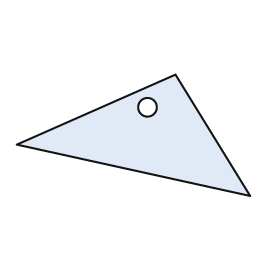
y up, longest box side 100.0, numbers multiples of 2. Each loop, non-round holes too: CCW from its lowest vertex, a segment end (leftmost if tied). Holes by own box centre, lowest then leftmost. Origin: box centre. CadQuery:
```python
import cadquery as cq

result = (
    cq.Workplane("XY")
    .moveTo(50.0, -26.0)
    .lineTo(18.0, 26.0)
    .lineTo(-50.0, -4.0)
    .close()
    .moveTo(6.0, 12.0)
    .circle(4.0)
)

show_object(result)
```